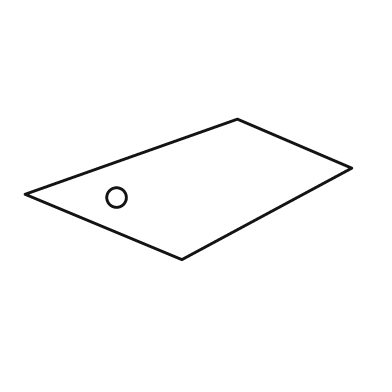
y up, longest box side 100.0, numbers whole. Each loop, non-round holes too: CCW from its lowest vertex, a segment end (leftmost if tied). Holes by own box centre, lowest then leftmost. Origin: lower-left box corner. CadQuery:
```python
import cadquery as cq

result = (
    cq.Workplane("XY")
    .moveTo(48.0, 0.0)
    .lineTo(100.0, 28.0)
    .lineTo(65.0, 43.0)
    .lineTo(0.0, 20.0)
    .close()
    .moveTo(28.0, 19.0)
    .circle(3.0)
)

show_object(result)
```